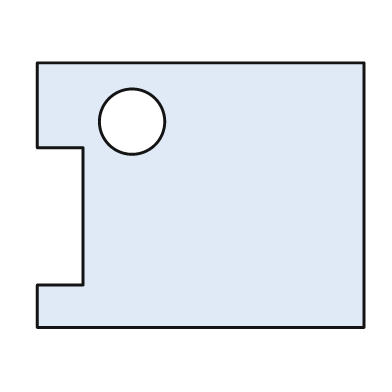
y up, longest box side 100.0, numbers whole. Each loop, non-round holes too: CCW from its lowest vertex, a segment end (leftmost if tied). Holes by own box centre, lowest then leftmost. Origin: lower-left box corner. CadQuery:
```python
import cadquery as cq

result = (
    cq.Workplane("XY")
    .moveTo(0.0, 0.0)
    .lineTo(100.0, 0.0)
    .lineTo(100.0, 81.0)
    .lineTo(0.0, 81.0)
    .lineTo(0.0, 55.0)
    .lineTo(14.0, 55.0)
    .lineTo(14.0, 13.0)
    .lineTo(0.0, 13.0)
    .close()
    .moveTo(29.0, 63.0)
    .circle(10.0)
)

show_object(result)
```